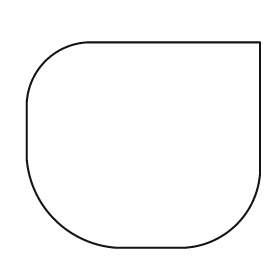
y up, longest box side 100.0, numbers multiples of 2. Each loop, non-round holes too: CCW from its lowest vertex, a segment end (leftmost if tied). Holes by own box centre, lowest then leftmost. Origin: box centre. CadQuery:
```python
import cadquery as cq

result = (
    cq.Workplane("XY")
    .moveTo(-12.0, -44.0)
    .lineTo(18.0, -44.0)
    .threePointArc((40.0, -34.0), (50.0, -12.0))
    .lineTo(50.0, 44.0)
    .lineTo(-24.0, 44.0)
    .threePointArc((-42.0, 36.0), (-50.0, 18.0))
    .lineTo(-50.0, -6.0)
    .threePointArc((-38.0, -32.0), (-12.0, -44.0))
    .close()
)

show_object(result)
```